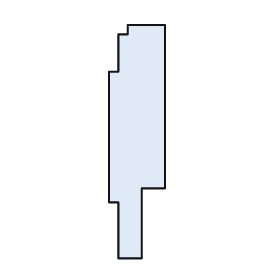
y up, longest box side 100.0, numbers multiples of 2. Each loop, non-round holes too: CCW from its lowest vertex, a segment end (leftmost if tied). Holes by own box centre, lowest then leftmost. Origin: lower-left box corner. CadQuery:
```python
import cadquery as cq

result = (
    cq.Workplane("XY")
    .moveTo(4.0, 0.0)
    .lineTo(14.0, 0.0)
    .lineTo(14.0, 30.0)
    .lineTo(24.0, 30.0)
    .lineTo(24.0, 100.0)
    .lineTo(8.0, 100.0)
    .lineTo(8.0, 96.0)
    .lineTo(4.0, 96.0)
    .lineTo(4.0, 80.0)
    .lineTo(0.0, 80.0)
    .lineTo(0.0, 24.0)
    .lineTo(4.0, 24.0)
    .close()
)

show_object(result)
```